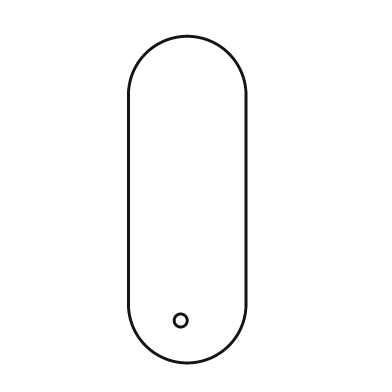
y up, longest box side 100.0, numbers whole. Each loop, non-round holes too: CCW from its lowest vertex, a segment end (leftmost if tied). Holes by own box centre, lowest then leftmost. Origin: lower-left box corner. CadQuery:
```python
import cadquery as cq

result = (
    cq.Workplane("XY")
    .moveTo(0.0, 18.0)
    .threePointArc((18.0, 0.0), (36.0, 18.0))
    .lineTo(36.0, 82.0)
    .threePointArc((18.0, 100.0), (0.0, 82.0))
    .close()
    .moveTo(16.0, 13.0)
    .circle(2.0)
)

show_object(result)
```